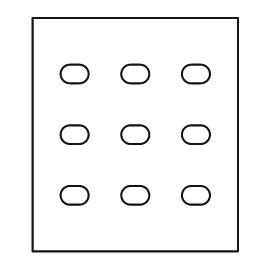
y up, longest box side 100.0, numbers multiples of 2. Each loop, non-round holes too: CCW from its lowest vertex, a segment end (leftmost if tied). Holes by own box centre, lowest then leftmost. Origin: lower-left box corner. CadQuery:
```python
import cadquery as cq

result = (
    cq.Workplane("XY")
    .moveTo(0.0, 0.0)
    .lineTo(88.0, 0.0)
    .lineTo(88.0, 100.0)
    .lineTo(0.0, 100.0)
    .close()
    .moveTo(16.0, 20.0)
    .lineTo(20.0, 20.0)
    .threePointArc((24.0, 24.0), (20.0, 28.0))
    .lineTo(16.0, 28.0)
    .threePointArc((12.0, 24.0), (16.0, 20.0))
    .close()
    .moveTo(42.0, 20.0)
    .lineTo(46.0, 20.0)
    .threePointArc((50.0, 24.0), (46.0, 28.0))
    .lineTo(42.0, 28.0)
    .threePointArc((38.0, 24.0), (42.0, 20.0))
    .close()
    .moveTo(68.0, 20.0)
    .lineTo(72.0, 20.0)
    .threePointArc((76.0, 24.0), (72.0, 28.0))
    .lineTo(68.0, 28.0)
    .threePointArc((64.0, 24.0), (68.0, 20.0))
    .close()
    .moveTo(16.0, 46.0)
    .lineTo(20.0, 46.0)
    .threePointArc((24.0, 50.0), (20.0, 54.0))
    .lineTo(16.0, 54.0)
    .threePointArc((12.0, 50.0), (16.0, 46.0))
    .close()
    .moveTo(42.0, 46.0)
    .lineTo(46.0, 46.0)
    .threePointArc((50.0, 50.0), (46.0, 54.0))
    .lineTo(42.0, 54.0)
    .threePointArc((38.0, 50.0), (42.0, 46.0))
    .close()
    .moveTo(68.0, 46.0)
    .lineTo(72.0, 46.0)
    .threePointArc((76.0, 50.0), (72.0, 54.0))
    .lineTo(68.0, 54.0)
    .threePointArc((64.0, 50.0), (68.0, 46.0))
    .close()
    .moveTo(16.0, 72.0)
    .lineTo(20.0, 72.0)
    .threePointArc((24.0, 76.0), (20.0, 80.0))
    .lineTo(16.0, 80.0)
    .threePointArc((12.0, 76.0), (16.0, 72.0))
    .close()
    .moveTo(42.0, 72.0)
    .lineTo(46.0, 72.0)
    .threePointArc((50.0, 76.0), (46.0, 80.0))
    .lineTo(42.0, 80.0)
    .threePointArc((38.0, 76.0), (42.0, 72.0))
    .close()
    .moveTo(68.0, 72.0)
    .lineTo(72.0, 72.0)
    .threePointArc((76.0, 76.0), (72.0, 80.0))
    .lineTo(68.0, 80.0)
    .threePointArc((64.0, 76.0), (68.0, 72.0))
    .close()
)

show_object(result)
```